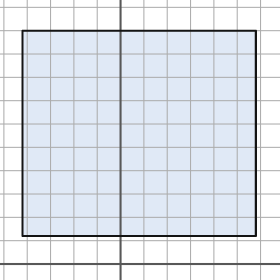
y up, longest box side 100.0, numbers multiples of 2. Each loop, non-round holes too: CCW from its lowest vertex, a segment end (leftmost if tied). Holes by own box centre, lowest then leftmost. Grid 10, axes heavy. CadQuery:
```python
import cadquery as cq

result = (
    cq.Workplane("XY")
    .moveTo(-42.0, 12.0)
    .lineTo(58.0, 12.0)
    .lineTo(58.0, 100.0)
    .lineTo(-42.0, 100.0)
    .close()
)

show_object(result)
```